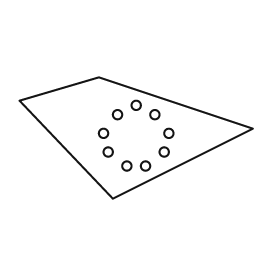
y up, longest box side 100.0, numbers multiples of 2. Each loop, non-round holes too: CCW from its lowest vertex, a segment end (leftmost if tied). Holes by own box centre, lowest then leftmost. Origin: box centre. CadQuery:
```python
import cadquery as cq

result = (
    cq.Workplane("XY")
    .moveTo(-10.0, -26.0)
    .lineTo(50.0, 4.0)
    .lineTo(-16.0, 26.0)
    .lineTo(-50.0, 16.0)
    .close()
    .moveTo(-4.0, -12.0)
    .circle(2.0)
    .moveTo(4.0, -12.0)
    .circle(2.0)
    .moveTo(-12.0, -6.0)
    .circle(2.0)
    .moveTo(12.0, -6.0)
    .circle(2.0)
    .moveTo(-14.0, 2.0)
    .circle(2.0)
    .moveTo(14.0, 2.0)
    .circle(2.0)
    .moveTo(-8.0, 10.0)
    .circle(2.0)
    .moveTo(8.0, 10.0)
    .circle(2.0)
    .moveTo(0.0, 14.0)
    .circle(2.0)
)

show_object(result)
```